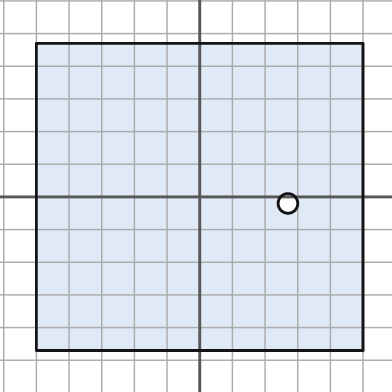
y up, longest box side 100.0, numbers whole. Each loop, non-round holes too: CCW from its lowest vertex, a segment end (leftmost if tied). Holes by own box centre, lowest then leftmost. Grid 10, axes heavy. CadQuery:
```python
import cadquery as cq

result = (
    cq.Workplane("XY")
    .moveTo(-50.0, -47.0)
    .lineTo(50.0, -47.0)
    .lineTo(50.0, 47.0)
    .lineTo(-50.0, 47.0)
    .close()
    .moveTo(27.0, -2.0)
    .circle(3.0)
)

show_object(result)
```